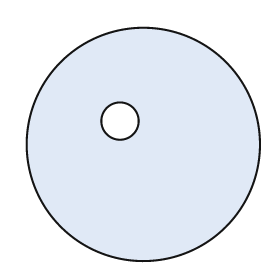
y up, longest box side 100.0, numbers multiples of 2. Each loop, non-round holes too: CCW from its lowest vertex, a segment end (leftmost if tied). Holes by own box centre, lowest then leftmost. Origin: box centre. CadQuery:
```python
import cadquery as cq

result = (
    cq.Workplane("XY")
    .moveTo(0.0, 0.0)
    .circle(50.0)
    .moveTo(-10.0, 10.0)
    .circle(8.0)
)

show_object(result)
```